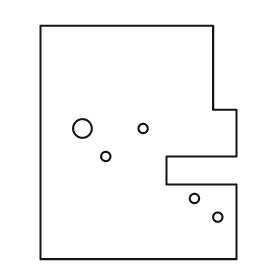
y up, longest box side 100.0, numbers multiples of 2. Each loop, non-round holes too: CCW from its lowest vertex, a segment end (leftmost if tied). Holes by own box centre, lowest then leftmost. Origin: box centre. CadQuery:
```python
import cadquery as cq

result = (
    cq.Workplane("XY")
    .moveTo(-42.0, -50.0)
    .lineTo(42.0, -50.0)
    .lineTo(42.0, -18.0)
    .lineTo(12.0, -18.0)
    .lineTo(12.0, -6.0)
    .lineTo(42.0, -6.0)
    .lineTo(42.0, 14.0)
    .lineTo(32.0, 14.0)
    .lineTo(32.0, 50.0)
    .lineTo(-42.0, 50.0)
    .close()
    .moveTo(34.0, -32.0)
    .circle(2.0)
    .moveTo(24.0, -24.0)
    .circle(2.0)
    .moveTo(-14.0, -6.0)
    .circle(2.0)
    .moveTo(-24.0, 6.0)
    .circle(4.0)
    .moveTo(2.0, 6.0)
    .circle(2.0)
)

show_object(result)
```